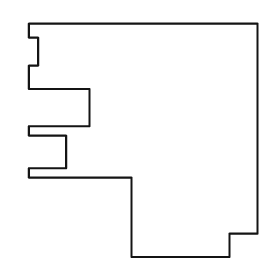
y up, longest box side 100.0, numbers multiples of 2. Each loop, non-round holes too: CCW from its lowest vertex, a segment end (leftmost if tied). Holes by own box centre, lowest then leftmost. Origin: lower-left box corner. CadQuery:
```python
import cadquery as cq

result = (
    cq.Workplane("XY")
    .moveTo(44.0, 0.0)
    .lineTo(86.0, 0.0)
    .lineTo(86.0, 10.0)
    .lineTo(98.0, 10.0)
    .lineTo(98.0, 100.0)
    .lineTo(0.0, 100.0)
    .lineTo(0.0, 94.0)
    .lineTo(4.0, 94.0)
    .lineTo(4.0, 82.0)
    .lineTo(0.0, 82.0)
    .lineTo(0.0, 72.0)
    .lineTo(26.0, 72.0)
    .lineTo(26.0, 56.0)
    .lineTo(0.0, 56.0)
    .lineTo(0.0, 52.0)
    .lineTo(16.0, 52.0)
    .lineTo(16.0, 38.0)
    .lineTo(0.0, 38.0)
    .lineTo(0.0, 34.0)
    .lineTo(44.0, 34.0)
    .close()
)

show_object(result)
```